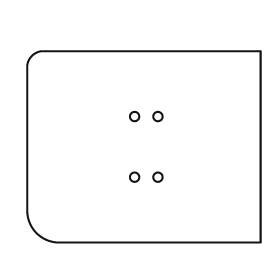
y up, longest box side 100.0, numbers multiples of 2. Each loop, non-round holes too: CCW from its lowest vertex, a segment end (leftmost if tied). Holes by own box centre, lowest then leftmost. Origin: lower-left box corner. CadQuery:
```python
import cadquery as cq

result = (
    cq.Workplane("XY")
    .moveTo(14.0, 0.0)
    .lineTo(100.0, 0.0)
    .lineTo(100.0, 82.0)
    .lineTo(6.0, 82.0)
    .threePointArc((2.0, 80.0), (0.0, 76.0))
    .lineTo(0.0, 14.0)
    .threePointArc((4.0, 4.0), (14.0, 0.0))
    .close()
    .moveTo(46.0, 28.0)
    .circle(2.0)
    .moveTo(56.0, 28.0)
    .circle(2.0)
    .moveTo(46.0, 54.0)
    .circle(2.0)
    .moveTo(56.0, 54.0)
    .circle(2.0)
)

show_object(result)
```